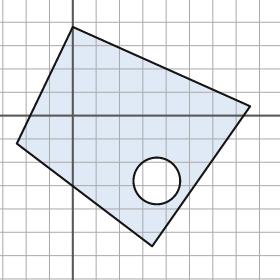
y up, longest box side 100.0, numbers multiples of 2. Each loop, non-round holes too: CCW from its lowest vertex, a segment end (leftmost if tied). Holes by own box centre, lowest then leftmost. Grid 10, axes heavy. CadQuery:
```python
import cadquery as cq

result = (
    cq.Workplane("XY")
    .moveTo(34.0, -56.0)
    .lineTo(76.0, 4.0)
    .lineTo(0.0, 38.0)
    .lineTo(-24.0, -12.0)
    .close()
    .moveTo(36.0, -28.0)
    .circle(10.0)
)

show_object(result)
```